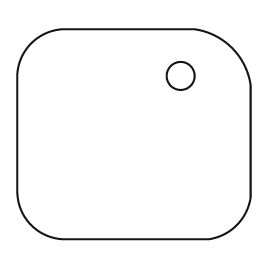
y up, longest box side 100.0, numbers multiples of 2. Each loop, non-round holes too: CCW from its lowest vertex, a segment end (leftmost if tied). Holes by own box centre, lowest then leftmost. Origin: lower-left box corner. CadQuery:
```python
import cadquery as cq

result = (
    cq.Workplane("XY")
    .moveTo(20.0, 0.0)
    .lineTo(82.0, 0.0)
    .threePointArc((94.0, 6.0), (100.0, 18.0))
    .lineTo(100.0, 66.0)
    .threePointArc((92.0, 82.0), (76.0, 90.0))
    .lineTo(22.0, 90.0)
    .threePointArc((6.0, 84.0), (0.0, 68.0))
    .lineTo(0.0, 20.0)
    .threePointArc((6.0, 6.0), (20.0, 0.0))
    .close()
    .moveTo(70.0, 70.0)
    .circle(6.0)
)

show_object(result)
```